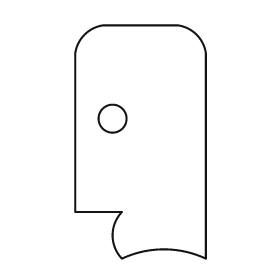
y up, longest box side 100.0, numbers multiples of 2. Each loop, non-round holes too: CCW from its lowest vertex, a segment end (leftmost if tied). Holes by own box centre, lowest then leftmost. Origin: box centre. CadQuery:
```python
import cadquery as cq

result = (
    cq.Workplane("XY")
    .moveTo(-8.0, -50.0)
    .threePointArc((10.0, -46.0), (28.0, -50.0))
    .lineTo(28.0, 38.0)
    .threePointArc((24.0, 46.0), (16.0, 50.0))
    .lineTo(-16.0, 50.0)
    .threePointArc((-24.0, 46.0), (-28.0, 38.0))
    .lineTo(-28.0, -30.0)
    .lineTo(-8.0, -30.0)
    .threePointArc((-12.0, -40.0), (-8.0, -50.0))
    .close()
    .moveTo(-12.0, 10.0)
    .circle(6.0)
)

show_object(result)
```